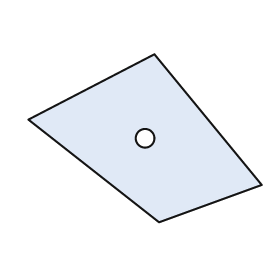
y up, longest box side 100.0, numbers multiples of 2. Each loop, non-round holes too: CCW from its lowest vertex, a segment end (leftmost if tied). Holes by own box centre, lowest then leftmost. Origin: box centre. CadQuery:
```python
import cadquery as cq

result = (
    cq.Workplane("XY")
    .moveTo(6.0, -36.0)
    .lineTo(50.0, -20.0)
    .lineTo(4.0, 36.0)
    .lineTo(-50.0, 8.0)
    .close()
    .moveTo(0.0, 0.0)
    .circle(4.0)
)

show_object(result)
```